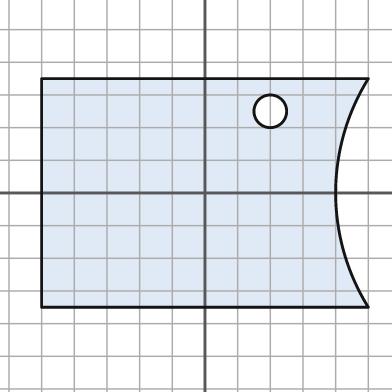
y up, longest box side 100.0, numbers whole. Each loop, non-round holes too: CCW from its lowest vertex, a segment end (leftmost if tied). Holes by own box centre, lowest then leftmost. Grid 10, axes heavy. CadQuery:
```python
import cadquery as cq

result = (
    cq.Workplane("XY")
    .moveTo(-50.0, -35.0)
    .lineTo(50.0, -35.0)
    .threePointArc((40.0, 0.0), (50.0, 35.0))
    .lineTo(-50.0, 35.0)
    .close()
    .moveTo(20.0, 25.0)
    .circle(5.0)
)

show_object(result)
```